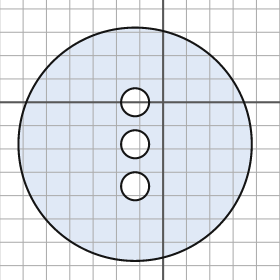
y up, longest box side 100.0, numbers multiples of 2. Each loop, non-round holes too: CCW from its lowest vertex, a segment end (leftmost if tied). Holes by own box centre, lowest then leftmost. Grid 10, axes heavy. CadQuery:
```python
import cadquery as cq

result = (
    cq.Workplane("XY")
    .moveTo(-12.0, -18.0)
    .circle(50.0)
    .moveTo(-12.0, -36.0)
    .circle(6.0)
    .moveTo(-12.0, -18.0)
    .circle(6.0)
    .moveTo(-12.0, 0.0)
    .circle(6.0)
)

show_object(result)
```